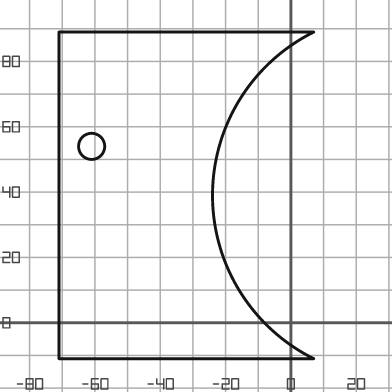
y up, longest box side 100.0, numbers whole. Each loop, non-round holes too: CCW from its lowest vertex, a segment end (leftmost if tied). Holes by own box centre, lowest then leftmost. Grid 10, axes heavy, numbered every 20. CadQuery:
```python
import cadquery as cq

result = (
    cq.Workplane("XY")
    .moveTo(-71.0, -11.0)
    .lineTo(7.0, -11.0)
    .threePointArc((-24.0, 39.0), (7.0, 89.0))
    .lineTo(-71.0, 89.0)
    .close()
    .moveTo(-61.0, 54.0)
    .circle(4.0)
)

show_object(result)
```